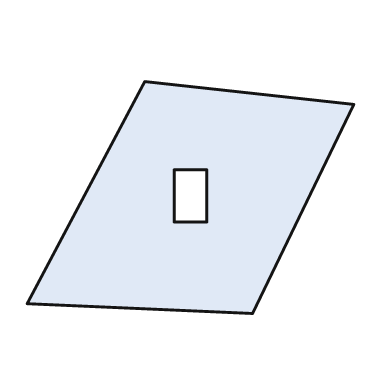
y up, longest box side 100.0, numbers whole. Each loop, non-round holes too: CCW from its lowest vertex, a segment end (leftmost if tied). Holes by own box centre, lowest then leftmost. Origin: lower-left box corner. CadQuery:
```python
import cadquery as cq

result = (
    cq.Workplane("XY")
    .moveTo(69.0, 0.0)
    .lineTo(100.0, 64.0)
    .lineTo(36.0, 71.0)
    .lineTo(0.0, 3.0)
    .close()
    .moveTo(45.0, 28.0)
    .lineTo(55.0, 28.0)
    .lineTo(55.0, 44.0)
    .lineTo(45.0, 44.0)
    .close()
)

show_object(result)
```